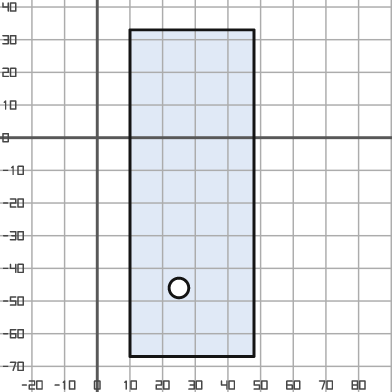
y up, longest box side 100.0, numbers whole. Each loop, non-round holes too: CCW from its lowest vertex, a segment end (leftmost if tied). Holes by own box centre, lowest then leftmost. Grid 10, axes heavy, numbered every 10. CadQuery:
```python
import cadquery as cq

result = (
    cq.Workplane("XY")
    .moveTo(10.0, -67.0)
    .lineTo(48.0, -67.0)
    .lineTo(48.0, 33.0)
    .lineTo(10.0, 33.0)
    .close()
    .moveTo(25.0, -46.0)
    .circle(3.0)
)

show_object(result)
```